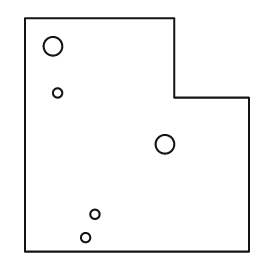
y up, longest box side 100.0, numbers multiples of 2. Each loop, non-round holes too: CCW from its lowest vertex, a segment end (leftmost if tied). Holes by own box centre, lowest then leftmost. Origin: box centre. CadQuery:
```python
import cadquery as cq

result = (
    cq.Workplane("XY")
    .moveTo(-48.0, -50.0)
    .lineTo(48.0, -50.0)
    .lineTo(48.0, 16.0)
    .lineTo(16.0, 16.0)
    .lineTo(16.0, 50.0)
    .lineTo(-48.0, 50.0)
    .close()
    .moveTo(-22.0, -44.0)
    .circle(2.0)
    .moveTo(-18.0, -34.0)
    .circle(2.0)
    .moveTo(12.0, -4.0)
    .circle(4.0)
    .moveTo(-34.0, 18.0)
    .circle(2.0)
    .moveTo(-36.0, 38.0)
    .circle(4.0)
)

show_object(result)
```